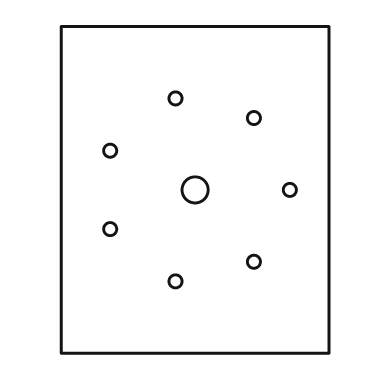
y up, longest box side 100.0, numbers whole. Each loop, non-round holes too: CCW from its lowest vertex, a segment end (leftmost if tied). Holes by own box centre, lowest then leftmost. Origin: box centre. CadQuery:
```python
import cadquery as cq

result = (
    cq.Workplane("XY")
    .moveTo(-41.0, -50.0)
    .lineTo(41.0, -50.0)
    .lineTo(41.0, 50.0)
    .lineTo(-41.0, 50.0)
    .close()
    .moveTo(-6.0, -28.0)
    .circle(2.0)
    .moveTo(18.0, -22.0)
    .circle(2.0)
    .moveTo(-26.0, -12.0)
    .circle(2.0)
    .moveTo(0.0, 0.0)
    .circle(4.0)
    .moveTo(29.0, 0.0)
    .circle(2.0)
    .moveTo(-26.0, 12.0)
    .circle(2.0)
    .moveTo(18.0, 22.0)
    .circle(2.0)
    .moveTo(-6.0, 28.0)
    .circle(2.0)
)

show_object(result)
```